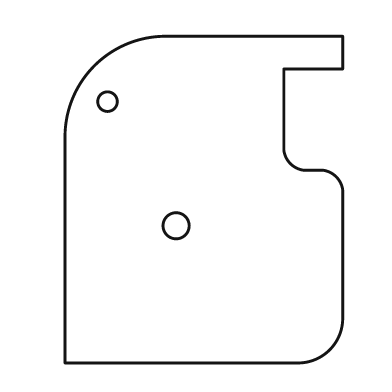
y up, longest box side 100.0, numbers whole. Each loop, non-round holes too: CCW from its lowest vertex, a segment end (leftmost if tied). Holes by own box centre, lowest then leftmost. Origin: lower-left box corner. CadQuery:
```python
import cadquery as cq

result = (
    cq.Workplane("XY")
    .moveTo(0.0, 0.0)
    .lineTo(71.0, 0.0)
    .threePointArc((81.0, 4.0), (85.0, 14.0))
    .lineTo(85.0, 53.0)
    .threePointArc((83.0, 57.0), (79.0, 59.0))
    .lineTo(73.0, 59.0)
    .threePointArc((69.0, 61.0), (67.0, 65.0))
    .lineTo(67.0, 90.0)
    .lineTo(85.0, 90.0)
    .lineTo(85.0, 100.0)
    .lineTo(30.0, 100.0)
    .threePointArc((9.0, 91.0), (0.0, 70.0))
    .close()
    .moveTo(34.0, 42.0)
    .circle(4.0)
    .moveTo(13.0, 80.0)
    .circle(3.0)
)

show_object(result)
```